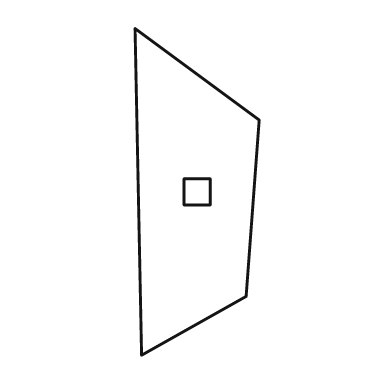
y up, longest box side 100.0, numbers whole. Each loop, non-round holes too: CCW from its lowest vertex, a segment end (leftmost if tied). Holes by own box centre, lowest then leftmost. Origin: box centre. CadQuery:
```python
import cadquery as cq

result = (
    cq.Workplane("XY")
    .moveTo(-17.0, -50.0)
    .lineTo(15.0, -32.0)
    .lineTo(19.0, 22.0)
    .lineTo(-19.0, 50.0)
    .close()
    .moveTo(-4.0, -4.0)
    .lineTo(4.0, -4.0)
    .lineTo(4.0, 4.0)
    .lineTo(-4.0, 4.0)
    .close()
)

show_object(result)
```